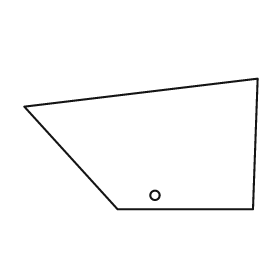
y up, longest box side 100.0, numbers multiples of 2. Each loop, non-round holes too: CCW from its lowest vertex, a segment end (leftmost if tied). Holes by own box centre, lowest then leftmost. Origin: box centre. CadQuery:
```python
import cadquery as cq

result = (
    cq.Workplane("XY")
    .moveTo(-10.0, -28.0)
    .lineTo(48.0, -28.0)
    .lineTo(50.0, 28.0)
    .lineTo(-50.0, 16.0)
    .close()
    .moveTo(6.0, -22.0)
    .circle(2.0)
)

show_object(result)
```